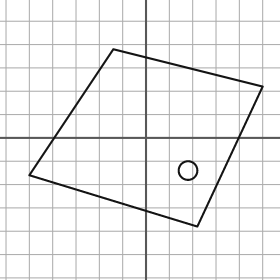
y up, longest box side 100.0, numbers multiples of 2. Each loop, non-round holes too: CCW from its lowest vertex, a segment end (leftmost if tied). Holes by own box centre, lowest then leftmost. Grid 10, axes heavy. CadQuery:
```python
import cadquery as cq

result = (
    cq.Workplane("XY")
    .moveTo(22.0, -38.0)
    .lineTo(50.0, 22.0)
    .lineTo(-14.0, 38.0)
    .lineTo(-50.0, -16.0)
    .close()
    .moveTo(18.0, -14.0)
    .circle(4.0)
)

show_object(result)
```